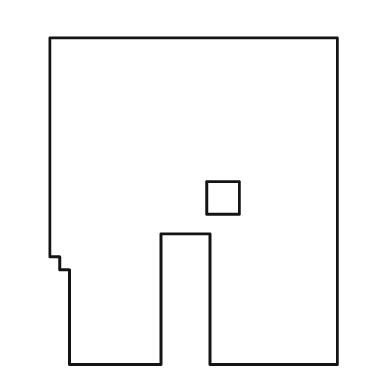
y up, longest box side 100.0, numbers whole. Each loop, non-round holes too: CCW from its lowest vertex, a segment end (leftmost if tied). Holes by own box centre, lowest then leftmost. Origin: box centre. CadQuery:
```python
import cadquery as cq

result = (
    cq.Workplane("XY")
    .moveTo(-38.0, -50.0)
    .lineTo(-10.0, -50.0)
    .lineTo(-10.0, -10.0)
    .lineTo(5.0, -10.0)
    .lineTo(5.0, -50.0)
    .lineTo(44.0, -50.0)
    .lineTo(44.0, 50.0)
    .lineTo(-44.0, 50.0)
    .lineTo(-44.0, -17.0)
    .lineTo(-41.0, -17.0)
    .lineTo(-41.0, -21.0)
    .lineTo(-38.0, -21.0)
    .close()
    .moveTo(4.0, -4.0)
    .lineTo(14.0, -4.0)
    .lineTo(14.0, 6.0)
    .lineTo(4.0, 6.0)
    .close()
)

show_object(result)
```